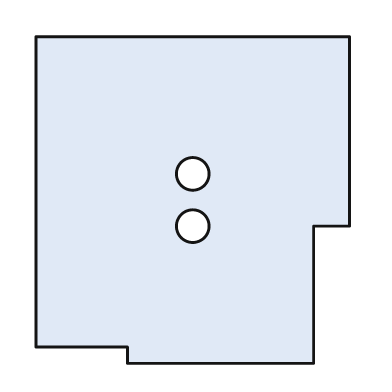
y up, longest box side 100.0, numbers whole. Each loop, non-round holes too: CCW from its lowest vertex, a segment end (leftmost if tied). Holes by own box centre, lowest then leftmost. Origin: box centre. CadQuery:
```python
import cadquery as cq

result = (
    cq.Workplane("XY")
    .moveTo(-20.0, -50.0)
    .lineTo(37.0, -50.0)
    .lineTo(37.0, -8.0)
    .lineTo(48.0, -8.0)
    .lineTo(48.0, 50.0)
    .lineTo(-48.0, 50.0)
    .lineTo(-48.0, -45.0)
    .lineTo(-20.0, -45.0)
    .close()
    .moveTo(0.0, -8.0)
    .circle(5.0)
    .moveTo(0.0, 8.0)
    .circle(5.0)
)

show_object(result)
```